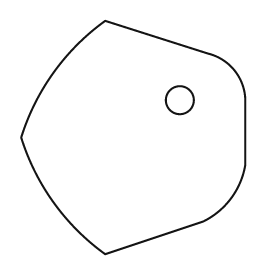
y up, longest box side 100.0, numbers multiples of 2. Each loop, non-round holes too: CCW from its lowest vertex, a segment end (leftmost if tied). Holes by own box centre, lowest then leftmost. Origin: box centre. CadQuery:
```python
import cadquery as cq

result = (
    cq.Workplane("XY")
    .moveTo(-12.0, -50.0)
    .lineTo(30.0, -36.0)
    .threePointArc((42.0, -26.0), (48.0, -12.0))
    .lineTo(48.0, 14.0)
    .threePointArc((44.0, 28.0), (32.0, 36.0))
    .lineTo(-12.0, 50.0)
    .threePointArc((-34.0, 28.0), (-48.0, 0.0))
    .threePointArc((-34.0, -28.0), (-12.0, -50.0))
    .close()
    .moveTo(20.0, 16.0)
    .circle(6.0)
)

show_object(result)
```